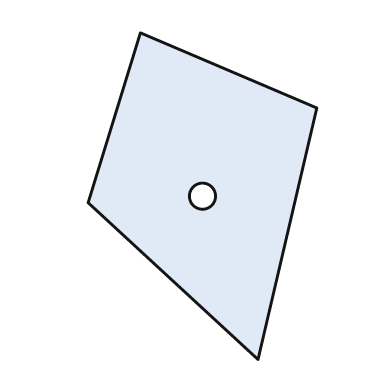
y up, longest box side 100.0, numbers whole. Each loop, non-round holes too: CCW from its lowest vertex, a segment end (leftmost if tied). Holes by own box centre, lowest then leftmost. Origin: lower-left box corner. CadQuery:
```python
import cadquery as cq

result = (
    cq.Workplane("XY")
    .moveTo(52.0, 0.0)
    .lineTo(70.0, 77.0)
    .lineTo(16.0, 100.0)
    .lineTo(0.0, 48.0)
    .close()
    .moveTo(35.0, 50.0)
    .circle(4.0)
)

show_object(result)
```